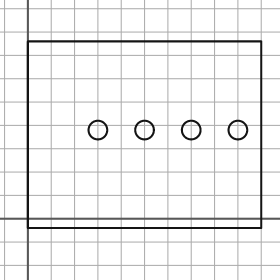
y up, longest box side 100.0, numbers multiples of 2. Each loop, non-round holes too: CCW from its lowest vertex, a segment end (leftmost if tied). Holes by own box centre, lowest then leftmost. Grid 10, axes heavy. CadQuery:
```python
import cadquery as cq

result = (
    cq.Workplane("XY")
    .moveTo(0.0, -4.0)
    .lineTo(100.0, -4.0)
    .lineTo(100.0, 76.0)
    .lineTo(0.0, 76.0)
    .close()
    .moveTo(30.0, 38.0)
    .circle(4.0)
    .moveTo(50.0, 38.0)
    .circle(4.0)
    .moveTo(70.0, 38.0)
    .circle(4.0)
    .moveTo(90.0, 38.0)
    .circle(4.0)
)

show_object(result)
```